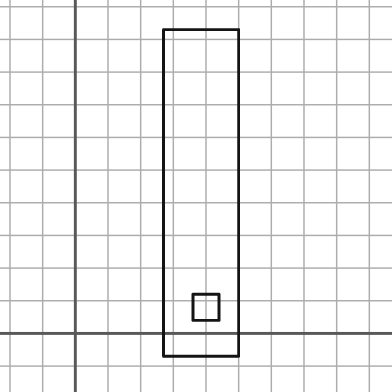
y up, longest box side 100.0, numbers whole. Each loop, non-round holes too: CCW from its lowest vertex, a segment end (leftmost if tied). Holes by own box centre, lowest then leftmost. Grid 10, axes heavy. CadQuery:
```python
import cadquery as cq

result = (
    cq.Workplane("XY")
    .moveTo(27.0, -7.0)
    .lineTo(50.0, -7.0)
    .lineTo(50.0, 93.0)
    .lineTo(27.0, 93.0)
    .close()
    .moveTo(36.0, 4.0)
    .lineTo(44.0, 4.0)
    .lineTo(44.0, 12.0)
    .lineTo(36.0, 12.0)
    .close()
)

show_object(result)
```